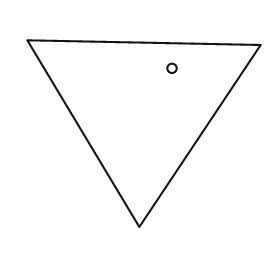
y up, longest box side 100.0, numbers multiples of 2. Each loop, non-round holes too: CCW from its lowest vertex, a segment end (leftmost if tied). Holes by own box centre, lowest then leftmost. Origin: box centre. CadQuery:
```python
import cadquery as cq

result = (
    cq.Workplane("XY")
    .moveTo(-2.0, -40.0)
    .lineTo(50.0, 38.0)
    .lineTo(-50.0, 40.0)
    .close()
    .moveTo(12.0, 28.0)
    .circle(2.0)
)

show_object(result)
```